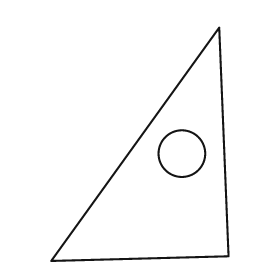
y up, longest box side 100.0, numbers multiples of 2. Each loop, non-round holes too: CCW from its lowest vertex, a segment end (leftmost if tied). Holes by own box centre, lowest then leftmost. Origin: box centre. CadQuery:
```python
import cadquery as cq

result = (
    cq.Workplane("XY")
    .moveTo(-38.0, -50.0)
    .lineTo(38.0, -48.0)
    .lineTo(34.0, 50.0)
    .close()
    .moveTo(18.0, -4.0)
    .circle(10.0)
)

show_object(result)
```